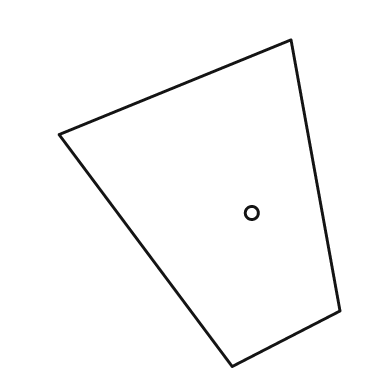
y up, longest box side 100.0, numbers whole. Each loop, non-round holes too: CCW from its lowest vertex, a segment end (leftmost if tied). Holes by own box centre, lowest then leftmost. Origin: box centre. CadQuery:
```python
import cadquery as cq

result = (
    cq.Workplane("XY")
    .moveTo(10.0, -50.0)
    .lineTo(43.0, -33.0)
    .lineTo(28.0, 50.0)
    .lineTo(-43.0, 21.0)
    .close()
    .moveTo(16.0, -3.0)
    .circle(2.0)
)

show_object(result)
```